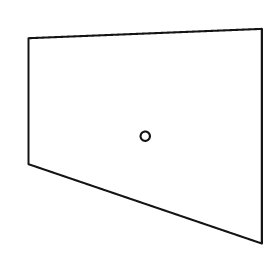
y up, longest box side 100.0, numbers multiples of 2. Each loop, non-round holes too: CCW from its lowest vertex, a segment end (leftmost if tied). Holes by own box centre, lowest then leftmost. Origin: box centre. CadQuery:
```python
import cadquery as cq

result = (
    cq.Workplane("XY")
    .moveTo(50.0, -46.0)
    .lineTo(50.0, 46.0)
    .lineTo(-50.0, 42.0)
    .lineTo(-50.0, -12.0)
    .close()
    .moveTo(0.0, 0.0)
    .circle(2.0)
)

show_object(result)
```